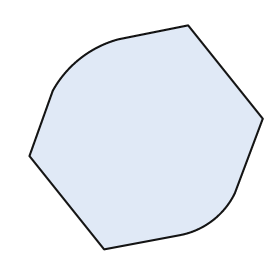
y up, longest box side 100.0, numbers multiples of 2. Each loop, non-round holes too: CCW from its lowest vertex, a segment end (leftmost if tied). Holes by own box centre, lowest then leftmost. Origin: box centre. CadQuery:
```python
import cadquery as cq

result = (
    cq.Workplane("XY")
    .moveTo(-18.0, -48.0)
    .lineTo(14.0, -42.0)
    .threePointArc((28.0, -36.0), (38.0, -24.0))
    .lineTo(50.0, 8.0)
    .lineTo(18.0, 48.0)
    .lineTo(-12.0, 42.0)
    .threePointArc((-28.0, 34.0), (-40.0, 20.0))
    .lineTo(-50.0, -8.0)
    .close()
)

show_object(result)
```